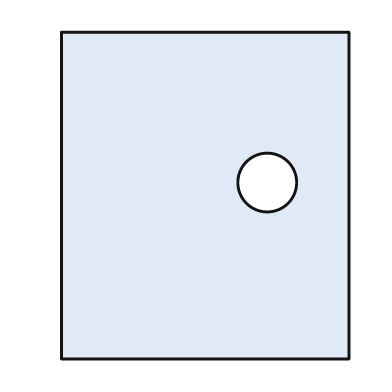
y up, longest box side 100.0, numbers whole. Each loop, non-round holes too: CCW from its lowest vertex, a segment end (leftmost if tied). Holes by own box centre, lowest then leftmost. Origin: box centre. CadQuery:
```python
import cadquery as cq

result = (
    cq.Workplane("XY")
    .moveTo(-44.0, -50.0)
    .lineTo(44.0, -50.0)
    .lineTo(44.0, 50.0)
    .lineTo(-44.0, 50.0)
    .close()
    .moveTo(19.0, 4.0)
    .circle(9.0)
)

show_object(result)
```